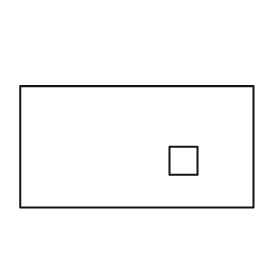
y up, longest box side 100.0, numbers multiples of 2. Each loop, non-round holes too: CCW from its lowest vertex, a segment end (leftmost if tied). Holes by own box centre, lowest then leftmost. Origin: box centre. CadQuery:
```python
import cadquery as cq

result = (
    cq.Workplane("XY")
    .moveTo(-50.0, -26.0)
    .lineTo(50.0, -26.0)
    .lineTo(50.0, 26.0)
    .lineTo(-50.0, 26.0)
    .close()
    .moveTo(14.0, -12.0)
    .lineTo(26.0, -12.0)
    .lineTo(26.0, 0.0)
    .lineTo(14.0, 0.0)
    .close()
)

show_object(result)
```